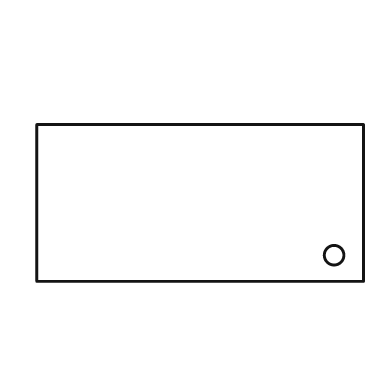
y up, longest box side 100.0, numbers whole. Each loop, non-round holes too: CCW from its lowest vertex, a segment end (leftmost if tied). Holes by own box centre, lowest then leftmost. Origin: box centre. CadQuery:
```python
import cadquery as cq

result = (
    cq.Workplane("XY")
    .moveTo(-50.0, -24.0)
    .lineTo(50.0, -24.0)
    .lineTo(50.0, 24.0)
    .lineTo(-50.0, 24.0)
    .close()
    .moveTo(41.0, -16.0)
    .circle(3.0)
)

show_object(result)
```